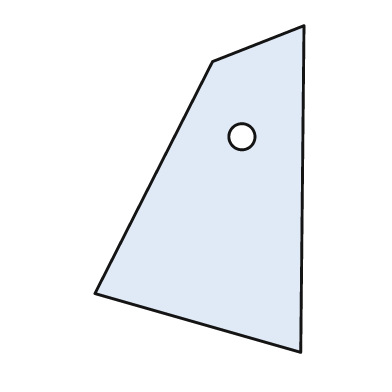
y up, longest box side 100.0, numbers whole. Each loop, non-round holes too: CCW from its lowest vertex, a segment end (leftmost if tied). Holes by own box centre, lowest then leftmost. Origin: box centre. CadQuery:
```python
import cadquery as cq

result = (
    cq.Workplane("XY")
    .moveTo(31.0, -50.0)
    .lineTo(32.0, 50.0)
    .lineTo(4.0, 39.0)
    .lineTo(-32.0, -32.0)
    .close()
    .moveTo(13.0, 16.0)
    .circle(4.0)
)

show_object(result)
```